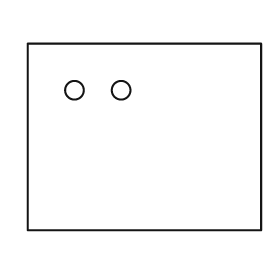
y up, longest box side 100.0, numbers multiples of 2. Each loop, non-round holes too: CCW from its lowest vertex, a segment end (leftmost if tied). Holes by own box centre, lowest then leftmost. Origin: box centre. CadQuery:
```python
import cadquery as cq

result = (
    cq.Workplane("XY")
    .moveTo(-50.0, -40.0)
    .lineTo(50.0, -40.0)
    .lineTo(50.0, 40.0)
    .lineTo(-50.0, 40.0)
    .close()
    .moveTo(-30.0, 20.0)
    .circle(4.0)
    .moveTo(-10.0, 20.0)
    .circle(4.0)
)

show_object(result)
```